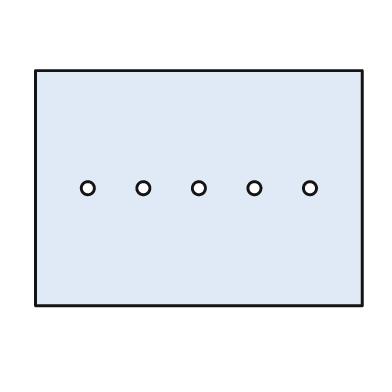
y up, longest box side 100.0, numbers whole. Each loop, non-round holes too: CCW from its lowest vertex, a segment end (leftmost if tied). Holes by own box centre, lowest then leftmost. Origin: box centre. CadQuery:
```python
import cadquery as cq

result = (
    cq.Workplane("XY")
    .moveTo(-50.0, -36.0)
    .lineTo(50.0, -36.0)
    .lineTo(50.0, 36.0)
    .lineTo(-50.0, 36.0)
    .close()
    .moveTo(-34.0, 0.0)
    .circle(2.0)
    .moveTo(-17.0, 0.0)
    .circle(2.0)
    .moveTo(0.0, 0.0)
    .circle(2.0)
    .moveTo(17.0, 0.0)
    .circle(2.0)
    .moveTo(34.0, 0.0)
    .circle(2.0)
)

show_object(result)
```